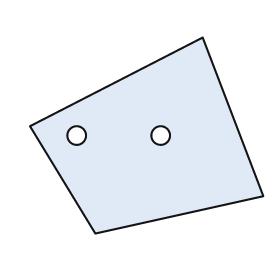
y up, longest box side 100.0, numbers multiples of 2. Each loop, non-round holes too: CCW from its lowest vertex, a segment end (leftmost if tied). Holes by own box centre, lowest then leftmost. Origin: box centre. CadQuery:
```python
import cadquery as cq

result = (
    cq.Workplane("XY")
    .moveTo(-22.0, -42.0)
    .lineTo(50.0, -26.0)
    .lineTo(24.0, 42.0)
    .lineTo(-50.0, 4.0)
    .close()
    .moveTo(-30.0, 0.0)
    .circle(4.0)
    .moveTo(6.0, 0.0)
    .circle(4.0)
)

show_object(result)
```